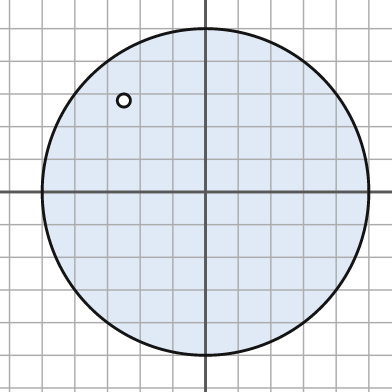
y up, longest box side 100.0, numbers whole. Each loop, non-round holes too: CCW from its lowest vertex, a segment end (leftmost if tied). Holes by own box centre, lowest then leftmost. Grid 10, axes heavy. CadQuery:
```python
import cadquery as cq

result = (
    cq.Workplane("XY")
    .moveTo(0.0, 0.0)
    .circle(50.0)
    .moveTo(-25.0, 28.0)
    .circle(2.0)
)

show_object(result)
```